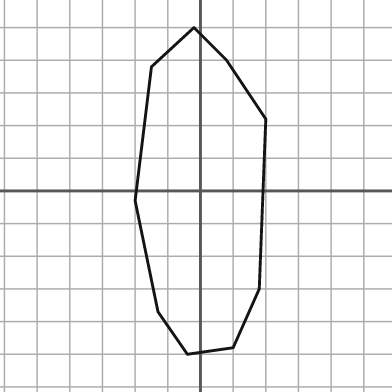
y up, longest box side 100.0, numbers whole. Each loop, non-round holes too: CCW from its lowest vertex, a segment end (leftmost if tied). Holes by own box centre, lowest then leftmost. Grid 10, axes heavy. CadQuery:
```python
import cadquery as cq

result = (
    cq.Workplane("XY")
    .moveTo(-4.0, -50.0)
    .lineTo(10.0, -48.0)
    .lineTo(18.0, -30.0)
    .lineTo(20.0, 22.0)
    .lineTo(8.0, 40.0)
    .lineTo(-2.0, 50.0)
    .lineTo(-15.0, 38.0)
    .lineTo(-20.0, -3.0)
    .lineTo(-13.0, -37.0)
    .close()
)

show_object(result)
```